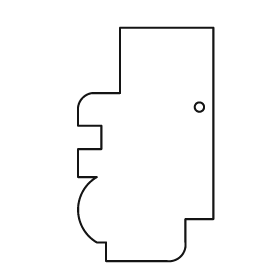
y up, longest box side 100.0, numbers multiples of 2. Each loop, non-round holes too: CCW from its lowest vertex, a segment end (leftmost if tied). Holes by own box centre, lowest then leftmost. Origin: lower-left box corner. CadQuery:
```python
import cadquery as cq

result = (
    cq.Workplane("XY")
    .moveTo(12.0, 0.0)
    .lineTo(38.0, 0.0)
    .threePointArc((44.0, 2.0), (46.0, 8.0))
    .lineTo(46.0, 18.0)
    .lineTo(58.0, 18.0)
    .lineTo(58.0, 100.0)
    .lineTo(18.0, 100.0)
    .lineTo(18.0, 72.0)
    .lineTo(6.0, 72.0)
    .threePointArc((2.0, 70.0), (0.0, 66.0))
    .lineTo(0.0, 58.0)
    .lineTo(10.0, 58.0)
    .lineTo(10.0, 48.0)
    .lineTo(0.0, 48.0)
    .lineTo(0.0, 36.0)
    .lineTo(8.0, 36.0)
    .threePointArc((0.0, 22.0), (8.0, 8.0))
    .lineTo(12.0, 8.0)
    .close()
    .moveTo(52.0, 66.0)
    .circle(2.0)
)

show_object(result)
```